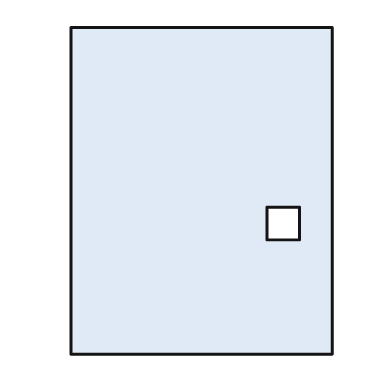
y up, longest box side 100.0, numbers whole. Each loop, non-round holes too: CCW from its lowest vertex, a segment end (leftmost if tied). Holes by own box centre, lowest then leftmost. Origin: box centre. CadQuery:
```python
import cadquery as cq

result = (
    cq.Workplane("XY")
    .moveTo(-40.0, -50.0)
    .lineTo(40.0, -50.0)
    .lineTo(40.0, 50.0)
    .lineTo(-40.0, 50.0)
    .close()
    .moveTo(20.0, -15.0)
    .lineTo(30.0, -15.0)
    .lineTo(30.0, -5.0)
    .lineTo(20.0, -5.0)
    .close()
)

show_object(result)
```